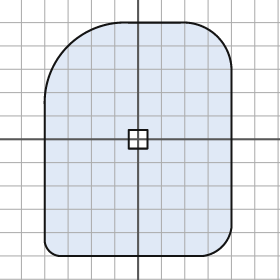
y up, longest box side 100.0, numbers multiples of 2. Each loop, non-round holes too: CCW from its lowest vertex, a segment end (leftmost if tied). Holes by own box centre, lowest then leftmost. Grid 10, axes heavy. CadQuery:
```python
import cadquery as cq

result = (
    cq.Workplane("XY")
    .moveTo(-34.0, -50.0)
    .lineTo(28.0, -50.0)
    .threePointArc((36.0, -46.0), (40.0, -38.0))
    .lineTo(40.0, 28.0)
    .threePointArc((34.0, 44.0), (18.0, 50.0))
    .lineTo(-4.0, 50.0)
    .threePointArc((-30.0, 40.0), (-40.0, 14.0))
    .lineTo(-40.0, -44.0)
    .threePointArc((-38.0, -48.0), (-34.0, -50.0))
    .close()
    .moveTo(-4.0, -4.0)
    .lineTo(4.0, -4.0)
    .lineTo(4.0, 4.0)
    .lineTo(-4.0, 4.0)
    .close()
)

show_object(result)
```